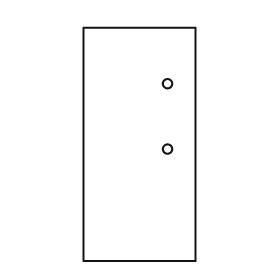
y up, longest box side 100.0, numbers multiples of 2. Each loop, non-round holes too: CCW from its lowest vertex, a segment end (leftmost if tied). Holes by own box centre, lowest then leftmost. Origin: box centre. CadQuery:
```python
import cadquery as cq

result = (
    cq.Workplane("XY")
    .moveTo(-24.0, -50.0)
    .lineTo(24.0, -50.0)
    .lineTo(24.0, 50.0)
    .lineTo(-24.0, 50.0)
    .close()
    .moveTo(12.0, -2.0)
    .circle(2.0)
    .moveTo(12.0, 26.0)
    .circle(2.0)
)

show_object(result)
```